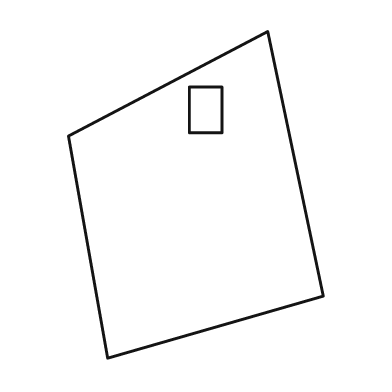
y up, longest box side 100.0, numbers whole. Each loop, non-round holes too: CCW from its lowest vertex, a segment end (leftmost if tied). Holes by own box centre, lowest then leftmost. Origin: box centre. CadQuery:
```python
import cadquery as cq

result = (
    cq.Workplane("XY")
    .moveTo(-27.0, -50.0)
    .lineTo(39.0, -31.0)
    .lineTo(22.0, 50.0)
    .lineTo(-39.0, 18.0)
    .close()
    .moveTo(-2.0, 19.0)
    .lineTo(8.0, 19.0)
    .lineTo(8.0, 33.0)
    .lineTo(-2.0, 33.0)
    .close()
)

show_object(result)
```